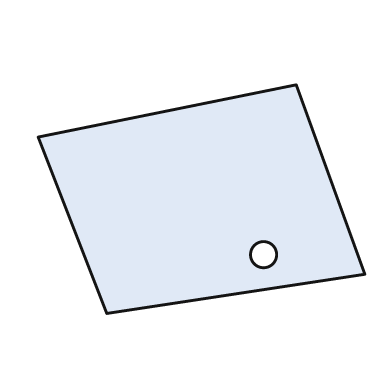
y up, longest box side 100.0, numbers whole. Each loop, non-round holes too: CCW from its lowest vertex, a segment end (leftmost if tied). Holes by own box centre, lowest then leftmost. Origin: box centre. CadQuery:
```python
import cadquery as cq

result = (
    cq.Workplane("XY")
    .moveTo(-29.0, -35.0)
    .lineTo(50.0, -23.0)
    .lineTo(29.0, 35.0)
    .lineTo(-50.0, 19.0)
    .close()
    .moveTo(19.0, -17.0)
    .circle(4.0)
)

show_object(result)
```